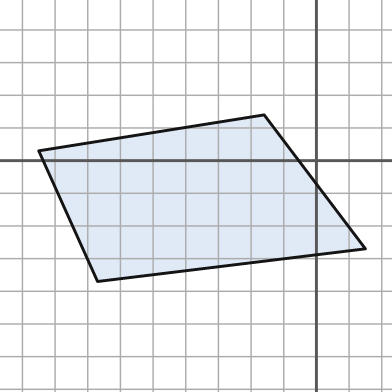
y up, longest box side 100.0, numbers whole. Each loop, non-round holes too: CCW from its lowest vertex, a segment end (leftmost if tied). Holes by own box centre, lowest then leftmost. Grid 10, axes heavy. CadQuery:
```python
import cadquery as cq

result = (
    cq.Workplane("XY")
    .moveTo(-67.0, -37.0)
    .lineTo(15.0, -27.0)
    .lineTo(-16.0, 14.0)
    .lineTo(-85.0, 3.0)
    .close()
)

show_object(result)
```